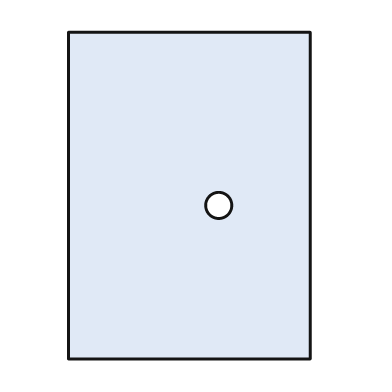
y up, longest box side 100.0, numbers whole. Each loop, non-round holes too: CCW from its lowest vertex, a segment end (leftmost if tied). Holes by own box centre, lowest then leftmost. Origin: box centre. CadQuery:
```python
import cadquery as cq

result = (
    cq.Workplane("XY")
    .moveTo(-37.0, -50.0)
    .lineTo(37.0, -50.0)
    .lineTo(37.0, 50.0)
    .lineTo(-37.0, 50.0)
    .close()
    .moveTo(9.0, -3.0)
    .circle(4.0)
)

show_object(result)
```